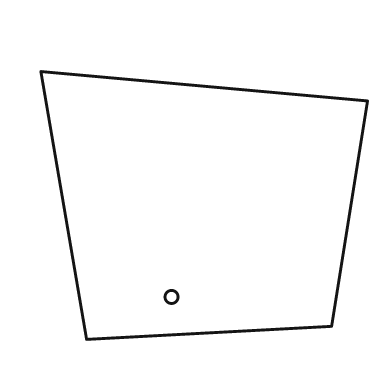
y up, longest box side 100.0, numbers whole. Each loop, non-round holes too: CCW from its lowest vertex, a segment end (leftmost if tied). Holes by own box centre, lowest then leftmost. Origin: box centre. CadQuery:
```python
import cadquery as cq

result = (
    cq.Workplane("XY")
    .moveTo(-36.0, -41.0)
    .lineTo(39.0, -37.0)
    .lineTo(50.0, 32.0)
    .lineTo(-50.0, 41.0)
    .close()
    .moveTo(-10.0, -28.0)
    .circle(2.0)
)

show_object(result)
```